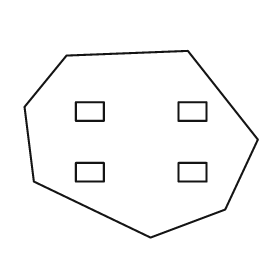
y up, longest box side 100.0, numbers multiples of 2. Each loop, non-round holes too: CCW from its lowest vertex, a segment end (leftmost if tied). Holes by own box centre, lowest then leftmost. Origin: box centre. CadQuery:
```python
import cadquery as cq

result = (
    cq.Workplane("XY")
    .moveTo(4.0, -40.0)
    .lineTo(36.0, -28.0)
    .lineTo(50.0, 2.0)
    .lineTo(20.0, 40.0)
    .lineTo(-32.0, 38.0)
    .lineTo(-50.0, 16.0)
    .lineTo(-46.0, -16.0)
    .close()
    .moveTo(-28.0, -16.0)
    .lineTo(-16.0, -16.0)
    .lineTo(-16.0, -8.0)
    .lineTo(-28.0, -8.0)
    .close()
    .moveTo(16.0, -16.0)
    .lineTo(28.0, -16.0)
    .lineTo(28.0, -8.0)
    .lineTo(16.0, -8.0)
    .close()
    .moveTo(-28.0, 10.0)
    .lineTo(-16.0, 10.0)
    .lineTo(-16.0, 18.0)
    .lineTo(-28.0, 18.0)
    .close()
    .moveTo(16.0, 10.0)
    .lineTo(28.0, 10.0)
    .lineTo(28.0, 18.0)
    .lineTo(16.0, 18.0)
    .close()
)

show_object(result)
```